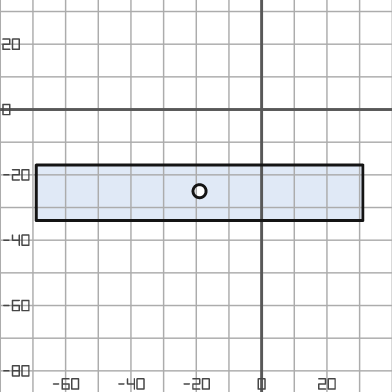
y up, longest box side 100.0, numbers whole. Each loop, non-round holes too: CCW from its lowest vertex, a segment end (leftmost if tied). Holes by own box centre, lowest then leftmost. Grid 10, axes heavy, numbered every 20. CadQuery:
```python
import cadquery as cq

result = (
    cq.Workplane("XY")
    .moveTo(-69.0, -34.0)
    .lineTo(31.0, -34.0)
    .lineTo(31.0, -17.0)
    .lineTo(-69.0, -17.0)
    .close()
    .moveTo(-19.0, -25.0)
    .circle(2.0)
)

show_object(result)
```